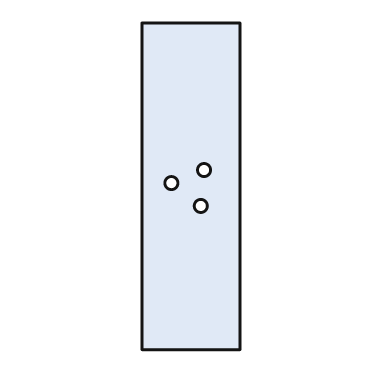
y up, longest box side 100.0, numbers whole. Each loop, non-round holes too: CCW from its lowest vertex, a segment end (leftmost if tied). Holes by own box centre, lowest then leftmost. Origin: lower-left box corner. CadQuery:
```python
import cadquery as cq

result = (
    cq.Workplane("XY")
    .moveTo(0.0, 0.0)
    .lineTo(30.0, 0.0)
    .lineTo(30.0, 100.0)
    .lineTo(0.0, 100.0)
    .close()
    .moveTo(18.0, 44.0)
    .circle(2.0)
    .moveTo(9.0, 51.0)
    .circle(2.0)
    .moveTo(19.0, 55.0)
    .circle(2.0)
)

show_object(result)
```